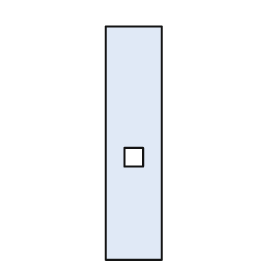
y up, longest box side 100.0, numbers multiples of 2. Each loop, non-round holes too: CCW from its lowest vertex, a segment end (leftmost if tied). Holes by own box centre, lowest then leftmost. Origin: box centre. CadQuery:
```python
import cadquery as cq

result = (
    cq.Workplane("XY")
    .moveTo(-12.0, -50.0)
    .lineTo(12.0, -50.0)
    .lineTo(12.0, 50.0)
    .lineTo(-12.0, 50.0)
    .close()
    .moveTo(-4.0, -10.0)
    .lineTo(4.0, -10.0)
    .lineTo(4.0, -2.0)
    .lineTo(-4.0, -2.0)
    .close()
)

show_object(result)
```